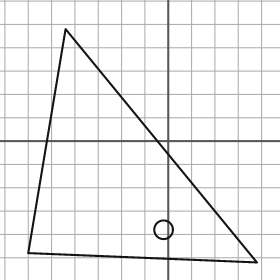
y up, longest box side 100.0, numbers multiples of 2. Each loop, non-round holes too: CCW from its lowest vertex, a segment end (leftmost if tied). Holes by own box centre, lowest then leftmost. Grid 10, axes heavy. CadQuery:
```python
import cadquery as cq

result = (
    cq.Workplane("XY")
    .moveTo(38.0, -52.0)
    .lineTo(-44.0, 48.0)
    .lineTo(-60.0, -48.0)
    .close()
    .moveTo(-2.0, -38.0)
    .circle(4.0)
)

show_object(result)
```